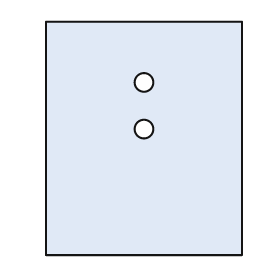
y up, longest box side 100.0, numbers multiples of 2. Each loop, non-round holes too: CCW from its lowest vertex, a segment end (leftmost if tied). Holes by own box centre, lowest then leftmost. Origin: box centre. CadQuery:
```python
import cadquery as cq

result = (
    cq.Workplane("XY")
    .moveTo(-42.0, -50.0)
    .lineTo(42.0, -50.0)
    .lineTo(42.0, 50.0)
    .lineTo(-42.0, 50.0)
    .close()
    .moveTo(0.0, 4.0)
    .circle(4.0)
    .moveTo(0.0, 24.0)
    .circle(4.0)
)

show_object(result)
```